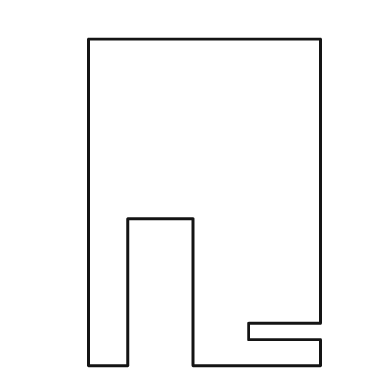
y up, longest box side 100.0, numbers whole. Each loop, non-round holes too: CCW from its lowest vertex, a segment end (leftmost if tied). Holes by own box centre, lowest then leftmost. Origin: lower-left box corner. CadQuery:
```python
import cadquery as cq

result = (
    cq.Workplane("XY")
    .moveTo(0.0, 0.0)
    .lineTo(12.0, 0.0)
    .lineTo(12.0, 45.0)
    .lineTo(32.0, 45.0)
    .lineTo(32.0, 0.0)
    .lineTo(71.0, 0.0)
    .lineTo(71.0, 8.0)
    .lineTo(49.0, 8.0)
    .lineTo(49.0, 13.0)
    .lineTo(71.0, 13.0)
    .lineTo(71.0, 100.0)
    .lineTo(0.0, 100.0)
    .close()
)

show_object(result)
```